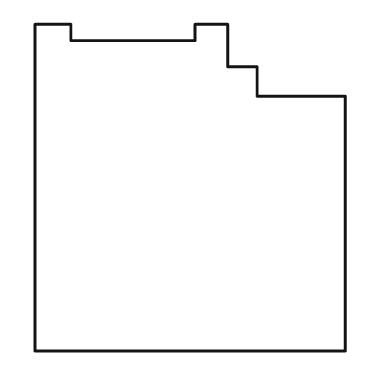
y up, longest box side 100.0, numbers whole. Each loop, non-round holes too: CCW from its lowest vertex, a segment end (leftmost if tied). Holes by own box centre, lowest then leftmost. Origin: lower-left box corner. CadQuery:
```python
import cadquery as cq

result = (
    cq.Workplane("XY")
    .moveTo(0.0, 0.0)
    .lineTo(95.0, 0.0)
    .lineTo(95.0, 78.0)
    .lineTo(68.0, 78.0)
    .lineTo(68.0, 87.0)
    .lineTo(59.0, 87.0)
    .lineTo(59.0, 100.0)
    .lineTo(49.0, 100.0)
    .lineTo(49.0, 95.0)
    .lineTo(11.0, 95.0)
    .lineTo(11.0, 100.0)
    .lineTo(0.0, 100.0)
    .close()
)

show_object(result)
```